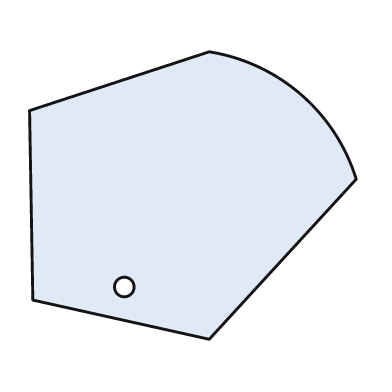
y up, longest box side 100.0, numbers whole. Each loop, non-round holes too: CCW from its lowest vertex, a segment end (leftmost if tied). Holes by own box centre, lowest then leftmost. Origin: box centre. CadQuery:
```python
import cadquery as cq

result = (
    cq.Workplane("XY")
    .moveTo(5.0, -44.0)
    .lineTo(50.0, 5.0)
    .threePointArc((33.0, 31.0), (5.0, 44.0))
    .lineTo(-50.0, 26.0)
    .lineTo(-49.0, -32.0)
    .close()
    .moveTo(-21.0, -28.0)
    .circle(3.0)
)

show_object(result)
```